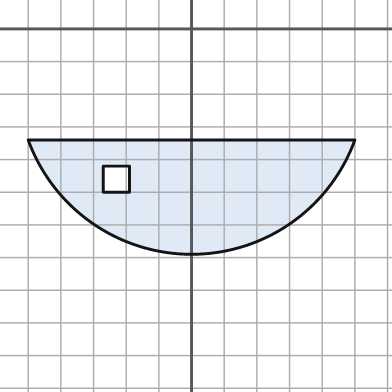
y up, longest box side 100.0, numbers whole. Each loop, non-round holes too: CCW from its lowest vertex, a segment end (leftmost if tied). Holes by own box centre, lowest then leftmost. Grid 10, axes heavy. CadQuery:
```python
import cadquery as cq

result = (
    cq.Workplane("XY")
    .moveTo(-50.0, -34.0)
    .threePointArc((0.0, -69.0), (50.0, -34.0))
    .close()
    .moveTo(-27.0, -50.0)
    .lineTo(-19.0, -50.0)
    .lineTo(-19.0, -42.0)
    .lineTo(-27.0, -42.0)
    .close()
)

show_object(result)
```